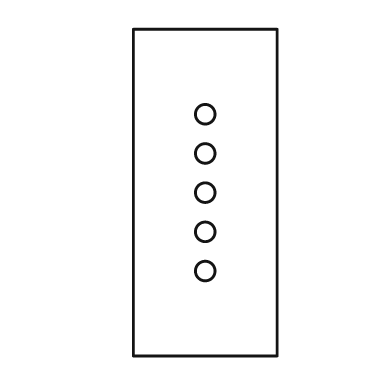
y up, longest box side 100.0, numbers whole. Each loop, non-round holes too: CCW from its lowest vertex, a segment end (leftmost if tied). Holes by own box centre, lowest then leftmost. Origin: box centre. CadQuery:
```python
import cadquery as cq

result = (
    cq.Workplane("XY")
    .moveTo(-22.0, -50.0)
    .lineTo(22.0, -50.0)
    .lineTo(22.0, 50.0)
    .lineTo(-22.0, 50.0)
    .close()
    .moveTo(0.0, -24.0)
    .circle(3.0)
    .moveTo(0.0, -12.0)
    .circle(3.0)
    .moveTo(0.0, 0.0)
    .circle(3.0)
    .moveTo(0.0, 12.0)
    .circle(3.0)
    .moveTo(0.0, 24.0)
    .circle(3.0)
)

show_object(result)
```